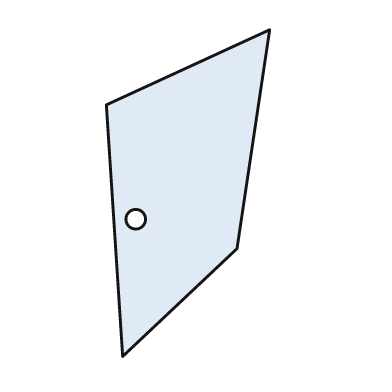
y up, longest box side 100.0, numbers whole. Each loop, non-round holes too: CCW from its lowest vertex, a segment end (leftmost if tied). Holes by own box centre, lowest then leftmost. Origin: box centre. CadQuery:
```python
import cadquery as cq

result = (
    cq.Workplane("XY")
    .moveTo(-20.0, -50.0)
    .lineTo(15.0, -17.0)
    .lineTo(25.0, 50.0)
    .lineTo(-25.0, 27.0)
    .close()
    .moveTo(-16.0, -8.0)
    .circle(3.0)
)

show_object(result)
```